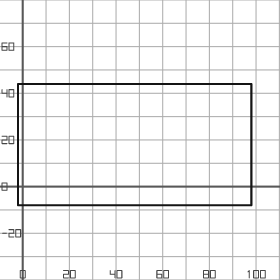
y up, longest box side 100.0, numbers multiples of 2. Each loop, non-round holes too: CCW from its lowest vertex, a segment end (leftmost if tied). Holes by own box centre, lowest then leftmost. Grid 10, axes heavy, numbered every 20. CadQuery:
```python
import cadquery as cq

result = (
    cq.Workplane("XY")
    .moveTo(-2.0, -8.0)
    .lineTo(98.0, -8.0)
    .lineTo(98.0, 44.0)
    .lineTo(-2.0, 44.0)
    .close()
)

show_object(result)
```